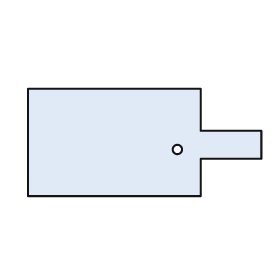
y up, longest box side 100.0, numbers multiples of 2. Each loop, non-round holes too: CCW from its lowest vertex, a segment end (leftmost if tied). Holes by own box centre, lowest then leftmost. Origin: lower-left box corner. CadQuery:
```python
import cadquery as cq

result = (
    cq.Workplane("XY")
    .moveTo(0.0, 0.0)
    .lineTo(74.0, 0.0)
    .lineTo(74.0, 16.0)
    .lineTo(100.0, 16.0)
    .lineTo(100.0, 28.0)
    .lineTo(74.0, 28.0)
    .lineTo(74.0, 46.0)
    .lineTo(0.0, 46.0)
    .close()
    .moveTo(64.0, 20.0)
    .circle(2.0)
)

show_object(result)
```